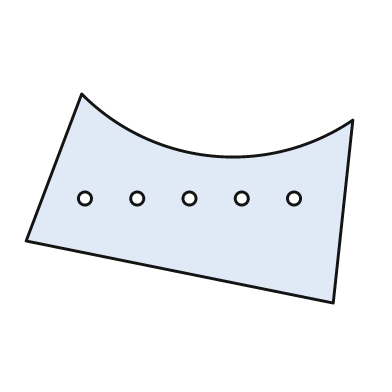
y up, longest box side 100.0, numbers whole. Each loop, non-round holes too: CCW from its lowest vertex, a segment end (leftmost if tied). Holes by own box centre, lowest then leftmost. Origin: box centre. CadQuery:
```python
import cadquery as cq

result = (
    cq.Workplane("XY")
    .moveTo(44.0, -32.0)
    .lineTo(50.0, 24.0)
    .threePointArc((7.0, 13.0), (-33.0, 32.0))
    .lineTo(-50.0, -13.0)
    .close()
    .moveTo(-32.0, 0.0)
    .circle(2.0)
    .moveTo(-16.0, 0.0)
    .circle(2.0)
    .moveTo(0.0, 0.0)
    .circle(2.0)
    .moveTo(16.0, 0.0)
    .circle(2.0)
    .moveTo(32.0, 0.0)
    .circle(2.0)
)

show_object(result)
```